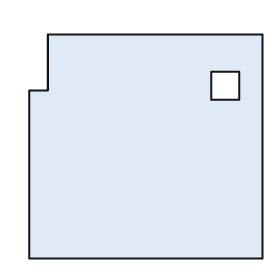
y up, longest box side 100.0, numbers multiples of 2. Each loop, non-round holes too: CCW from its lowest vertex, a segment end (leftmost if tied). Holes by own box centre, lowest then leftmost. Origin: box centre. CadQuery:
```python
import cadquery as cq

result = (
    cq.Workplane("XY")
    .moveTo(-50.0, -48.0)
    .lineTo(50.0, -48.0)
    .lineTo(50.0, 48.0)
    .lineTo(-42.0, 48.0)
    .lineTo(-42.0, 24.0)
    .lineTo(-50.0, 24.0)
    .close()
    .moveTo(28.0, 20.0)
    .lineTo(40.0, 20.0)
    .lineTo(40.0, 32.0)
    .lineTo(28.0, 32.0)
    .close()
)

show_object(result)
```